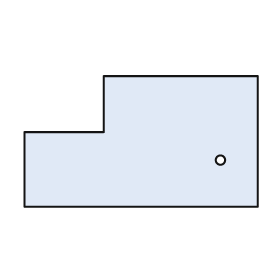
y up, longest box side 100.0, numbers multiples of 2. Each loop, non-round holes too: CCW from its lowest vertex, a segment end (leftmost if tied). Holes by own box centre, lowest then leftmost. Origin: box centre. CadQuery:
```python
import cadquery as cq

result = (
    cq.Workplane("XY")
    .moveTo(-50.0, -28.0)
    .lineTo(50.0, -28.0)
    .lineTo(50.0, 28.0)
    .lineTo(-16.0, 28.0)
    .lineTo(-16.0, 4.0)
    .lineTo(-50.0, 4.0)
    .close()
    .moveTo(34.0, -8.0)
    .circle(2.0)
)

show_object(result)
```